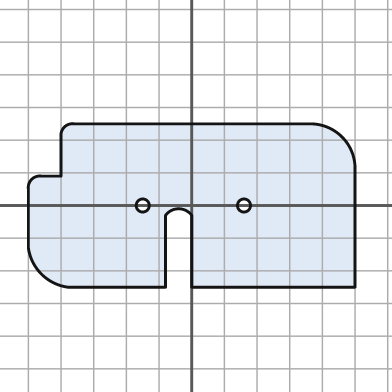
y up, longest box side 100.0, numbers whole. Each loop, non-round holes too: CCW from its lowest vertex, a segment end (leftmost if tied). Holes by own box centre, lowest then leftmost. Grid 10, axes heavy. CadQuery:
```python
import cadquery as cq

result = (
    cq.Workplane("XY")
    .moveTo(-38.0, -25.0)
    .lineTo(-8.0, -25.0)
    .lineTo(-8.0, -3.0)
    .threePointArc((-4.0, -1.0), (0.0, -3.0))
    .lineTo(0.0, -25.0)
    .lineTo(50.0, -25.0)
    .lineTo(50.0, 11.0)
    .threePointArc((46.0, 21.0), (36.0, 25.0))
    .lineTo(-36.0, 25.0)
    .threePointArc((-39.0, 24.0), (-40.0, 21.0))
    .lineTo(-40.0, 9.0)
    .lineTo(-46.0, 9.0)
    .threePointArc((-49.0, 8.0), (-50.0, 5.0))
    .lineTo(-50.0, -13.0)
    .threePointArc((-46.0, -21.0), (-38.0, -25.0))
    .close()
    .moveTo(-15.0, 0.0)
    .circle(2.0)
    .moveTo(16.0, 0.0)
    .circle(2.0)
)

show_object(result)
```